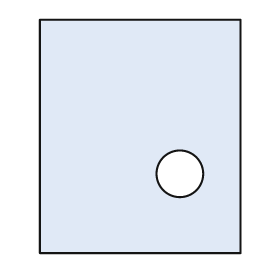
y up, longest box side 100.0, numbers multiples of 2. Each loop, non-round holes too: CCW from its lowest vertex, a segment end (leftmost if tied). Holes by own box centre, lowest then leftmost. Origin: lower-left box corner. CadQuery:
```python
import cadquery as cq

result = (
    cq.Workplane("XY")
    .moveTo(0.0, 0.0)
    .lineTo(86.0, 0.0)
    .lineTo(86.0, 100.0)
    .lineTo(0.0, 100.0)
    .close()
    .moveTo(60.0, 34.0)
    .circle(10.0)
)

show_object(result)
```